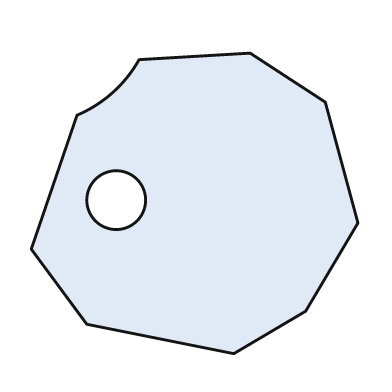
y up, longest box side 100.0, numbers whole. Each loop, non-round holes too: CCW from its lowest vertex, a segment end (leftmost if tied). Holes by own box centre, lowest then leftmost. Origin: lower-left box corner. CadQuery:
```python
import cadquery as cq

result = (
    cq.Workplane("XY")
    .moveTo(62.0, 0.0)
    .lineTo(84.0, 13.0)
    .lineTo(100.0, 40.0)
    .lineTo(90.0, 77.0)
    .lineTo(67.0, 92.0)
    .lineTo(33.0, 90.0)
    .threePointArc((25.0, 80.0), (14.0, 73.0))
    .lineTo(0.0, 32.0)
    .lineTo(17.0, 9.0)
    .close()
    .moveTo(26.0, 47.0)
    .circle(9.0)
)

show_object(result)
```